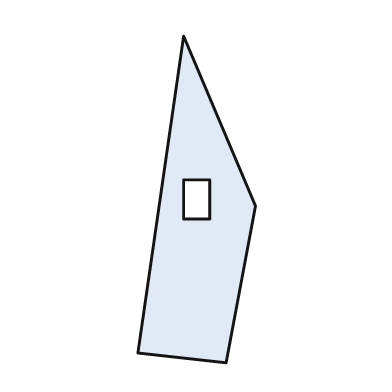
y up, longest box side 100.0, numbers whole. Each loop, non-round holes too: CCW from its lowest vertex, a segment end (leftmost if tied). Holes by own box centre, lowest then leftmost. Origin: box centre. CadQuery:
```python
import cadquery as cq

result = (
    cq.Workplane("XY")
    .moveTo(9.0, -50.0)
    .lineTo(18.0, -2.0)
    .lineTo(-4.0, 50.0)
    .lineTo(-18.0, -47.0)
    .close()
    .moveTo(-4.0, -6.0)
    .lineTo(4.0, -6.0)
    .lineTo(4.0, 6.0)
    .lineTo(-4.0, 6.0)
    .close()
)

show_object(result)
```